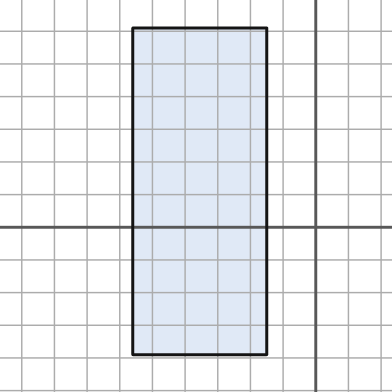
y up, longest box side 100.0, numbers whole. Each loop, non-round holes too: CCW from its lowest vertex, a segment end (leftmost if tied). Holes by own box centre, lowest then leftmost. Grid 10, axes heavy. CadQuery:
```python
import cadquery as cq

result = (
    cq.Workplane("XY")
    .moveTo(-56.0, -39.0)
    .lineTo(-15.0, -39.0)
    .lineTo(-15.0, 61.0)
    .lineTo(-56.0, 61.0)
    .close()
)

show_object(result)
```